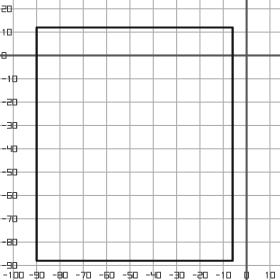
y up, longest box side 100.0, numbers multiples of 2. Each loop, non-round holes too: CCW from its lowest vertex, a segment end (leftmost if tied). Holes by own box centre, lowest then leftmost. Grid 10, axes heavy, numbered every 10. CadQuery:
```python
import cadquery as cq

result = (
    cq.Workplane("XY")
    .moveTo(-90.0, -88.0)
    .lineTo(-6.0, -88.0)
    .lineTo(-6.0, 12.0)
    .lineTo(-90.0, 12.0)
    .close()
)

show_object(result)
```